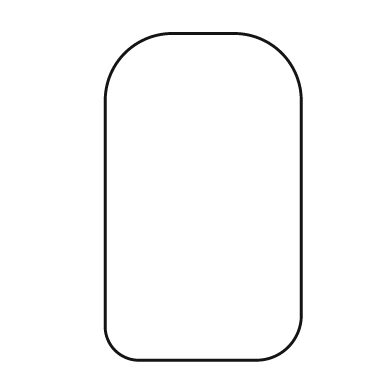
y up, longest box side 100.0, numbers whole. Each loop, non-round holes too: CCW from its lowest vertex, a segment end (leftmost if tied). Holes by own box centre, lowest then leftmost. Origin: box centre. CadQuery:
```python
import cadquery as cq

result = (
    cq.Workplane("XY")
    .moveTo(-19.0, -50.0)
    .lineTo(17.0, -50.0)
    .threePointArc((26.0, -46.0), (30.0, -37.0))
    .lineTo(30.0, 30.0)
    .threePointArc((24.0, 44.0), (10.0, 50.0))
    .lineTo(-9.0, 50.0)
    .threePointArc((-24.0, 44.0), (-30.0, 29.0))
    .lineTo(-30.0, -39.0)
    .threePointArc((-27.0, -47.0), (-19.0, -50.0))
    .close()
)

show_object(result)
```